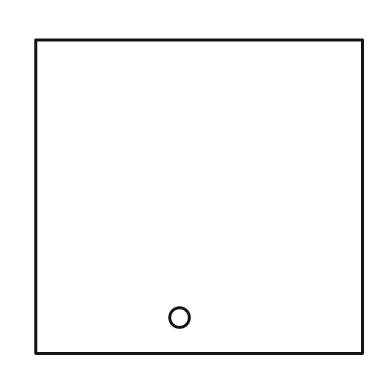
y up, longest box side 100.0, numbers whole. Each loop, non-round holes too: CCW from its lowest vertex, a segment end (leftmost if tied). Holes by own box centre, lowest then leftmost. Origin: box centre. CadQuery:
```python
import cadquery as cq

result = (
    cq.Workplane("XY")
    .moveTo(-50.0, -48.0)
    .lineTo(50.0, -48.0)
    .lineTo(50.0, 48.0)
    .lineTo(-50.0, 48.0)
    .close()
    .moveTo(-6.0, -37.0)
    .circle(3.0)
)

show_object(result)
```